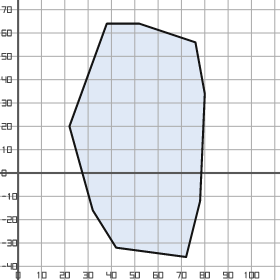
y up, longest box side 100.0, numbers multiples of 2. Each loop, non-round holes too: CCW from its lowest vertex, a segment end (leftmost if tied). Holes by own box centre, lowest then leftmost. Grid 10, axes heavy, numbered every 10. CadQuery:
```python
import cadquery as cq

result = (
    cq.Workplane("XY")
    .moveTo(72.0, -36.0)
    .lineTo(78.0, -12.0)
    .lineTo(80.0, 34.0)
    .lineTo(76.0, 56.0)
    .lineTo(52.0, 64.0)
    .lineTo(38.0, 64.0)
    .lineTo(22.0, 20.0)
    .lineTo(32.0, -16.0)
    .lineTo(42.0, -32.0)
    .close()
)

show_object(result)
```